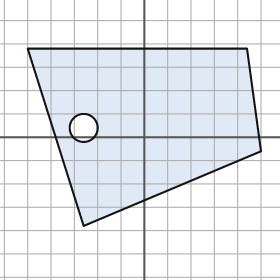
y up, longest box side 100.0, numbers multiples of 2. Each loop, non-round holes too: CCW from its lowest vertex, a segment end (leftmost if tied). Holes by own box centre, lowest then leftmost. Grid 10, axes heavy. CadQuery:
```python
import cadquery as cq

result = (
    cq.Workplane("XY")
    .moveTo(-26.0, -38.0)
    .lineTo(50.0, -6.0)
    .lineTo(44.0, 38.0)
    .lineTo(-50.0, 38.0)
    .close()
    .moveTo(-26.0, 4.0)
    .circle(6.0)
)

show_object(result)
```